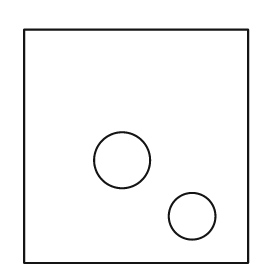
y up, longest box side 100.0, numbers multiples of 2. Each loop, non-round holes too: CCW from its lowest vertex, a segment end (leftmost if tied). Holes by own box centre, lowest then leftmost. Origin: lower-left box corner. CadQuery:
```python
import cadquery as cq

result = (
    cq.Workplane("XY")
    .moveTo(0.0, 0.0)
    .lineTo(96.0, 0.0)
    .lineTo(96.0, 100.0)
    .lineTo(0.0, 100.0)
    .close()
    .moveTo(72.0, 20.0)
    .circle(10.0)
    .moveTo(42.0, 44.0)
    .circle(12.0)
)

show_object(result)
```